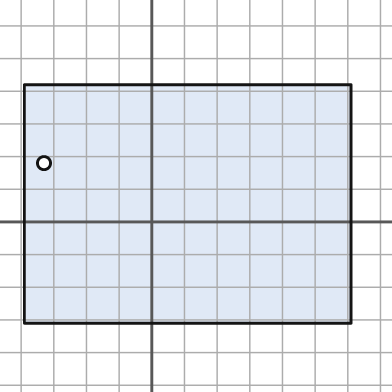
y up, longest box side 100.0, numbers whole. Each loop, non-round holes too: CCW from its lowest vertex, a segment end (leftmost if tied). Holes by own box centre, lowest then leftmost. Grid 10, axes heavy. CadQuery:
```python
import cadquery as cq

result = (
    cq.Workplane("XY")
    .moveTo(-39.0, -31.0)
    .lineTo(61.0, -31.0)
    .lineTo(61.0, 42.0)
    .lineTo(-39.0, 42.0)
    .close()
    .moveTo(-33.0, 18.0)
    .circle(2.0)
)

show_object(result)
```